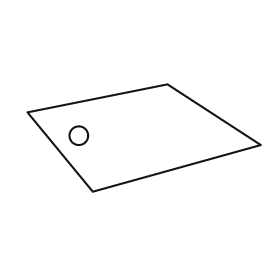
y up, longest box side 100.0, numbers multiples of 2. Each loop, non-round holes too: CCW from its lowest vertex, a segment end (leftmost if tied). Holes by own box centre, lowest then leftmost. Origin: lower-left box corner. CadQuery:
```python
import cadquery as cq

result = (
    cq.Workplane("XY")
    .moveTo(28.0, 0.0)
    .lineTo(100.0, 20.0)
    .lineTo(60.0, 46.0)
    .lineTo(0.0, 34.0)
    .close()
    .moveTo(22.0, 24.0)
    .circle(4.0)
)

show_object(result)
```